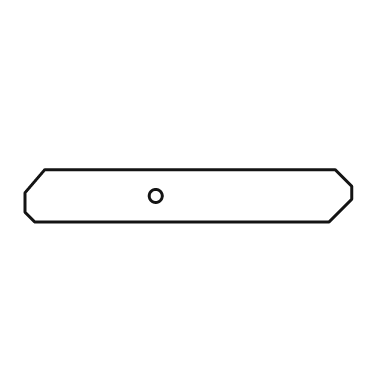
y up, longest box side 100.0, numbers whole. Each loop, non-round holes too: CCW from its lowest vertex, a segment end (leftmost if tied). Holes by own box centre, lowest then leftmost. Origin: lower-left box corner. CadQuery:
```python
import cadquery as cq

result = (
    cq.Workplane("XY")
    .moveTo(3.0, 0.0)
    .lineTo(93.0, 0.0)
    .lineTo(100.0, 7.0)
    .lineTo(100.0, 11.0)
    .lineTo(95.0, 16.0)
    .lineTo(6.0, 16.0)
    .lineTo(0.0, 9.0)
    .lineTo(0.0, 3.0)
    .close()
    .moveTo(40.0, 8.0)
    .circle(2.0)
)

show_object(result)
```